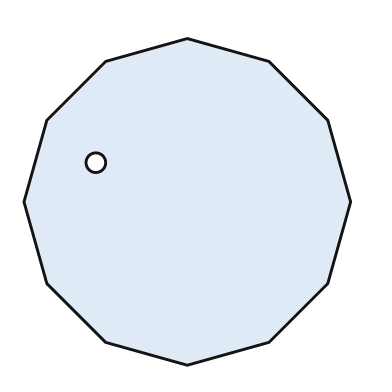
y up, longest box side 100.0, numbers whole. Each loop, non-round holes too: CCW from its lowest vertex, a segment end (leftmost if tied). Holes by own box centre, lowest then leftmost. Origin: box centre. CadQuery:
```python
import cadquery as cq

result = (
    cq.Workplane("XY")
    .moveTo(0.0, -50.0)
    .lineTo(25.0, -43.0)
    .lineTo(43.0, -25.0)
    .lineTo(50.0, 0.0)
    .lineTo(43.0, 25.0)
    .lineTo(25.0, 43.0)
    .lineTo(0.0, 50.0)
    .lineTo(-25.0, 43.0)
    .lineTo(-43.0, 25.0)
    .lineTo(-50.0, 0.0)
    .lineTo(-43.0, -25.0)
    .lineTo(-25.0, -43.0)
    .close()
    .moveTo(-28.0, 12.0)
    .circle(3.0)
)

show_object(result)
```